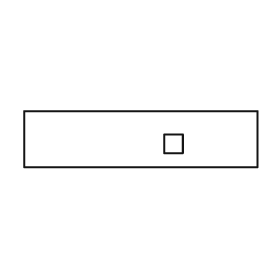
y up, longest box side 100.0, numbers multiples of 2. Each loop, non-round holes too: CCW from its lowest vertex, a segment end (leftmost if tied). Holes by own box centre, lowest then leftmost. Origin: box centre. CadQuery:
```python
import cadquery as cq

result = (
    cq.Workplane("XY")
    .moveTo(-50.0, -12.0)
    .lineTo(50.0, -12.0)
    .lineTo(50.0, 12.0)
    .lineTo(-50.0, 12.0)
    .close()
    .moveTo(10.0, -6.0)
    .lineTo(18.0, -6.0)
    .lineTo(18.0, 2.0)
    .lineTo(10.0, 2.0)
    .close()
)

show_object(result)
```